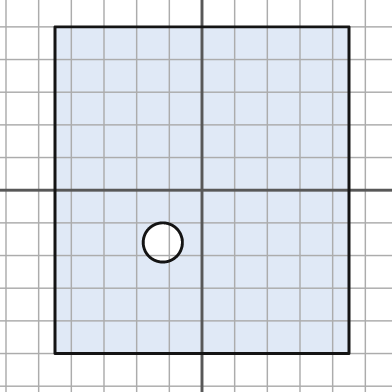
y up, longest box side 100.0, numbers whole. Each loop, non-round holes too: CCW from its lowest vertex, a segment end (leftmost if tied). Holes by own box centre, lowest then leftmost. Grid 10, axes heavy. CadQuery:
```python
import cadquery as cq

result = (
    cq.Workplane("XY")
    .moveTo(-45.0, -50.0)
    .lineTo(45.0, -50.0)
    .lineTo(45.0, 50.0)
    .lineTo(-45.0, 50.0)
    .close()
    .moveTo(-12.0, -16.0)
    .circle(6.0)
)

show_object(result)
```